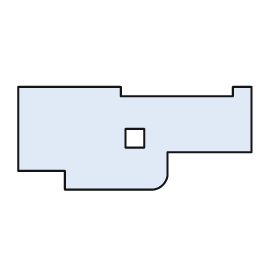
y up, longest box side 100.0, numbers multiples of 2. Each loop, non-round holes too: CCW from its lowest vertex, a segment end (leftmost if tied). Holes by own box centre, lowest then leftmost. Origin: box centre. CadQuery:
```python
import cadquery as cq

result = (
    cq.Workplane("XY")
    .moveTo(-30.0, -22.0)
    .lineTo(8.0, -22.0)
    .threePointArc((12.0, -20.0), (14.0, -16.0))
    .lineTo(14.0, -6.0)
    .lineTo(50.0, -6.0)
    .lineTo(50.0, 22.0)
    .lineTo(42.0, 22.0)
    .lineTo(42.0, 18.0)
    .lineTo(-6.0, 18.0)
    .lineTo(-6.0, 22.0)
    .lineTo(-50.0, 22.0)
    .lineTo(-50.0, -14.0)
    .lineTo(-30.0, -14.0)
    .close()
    .moveTo(-4.0, -4.0)
    .lineTo(4.0, -4.0)
    .lineTo(4.0, 4.0)
    .lineTo(-4.0, 4.0)
    .close()
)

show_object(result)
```